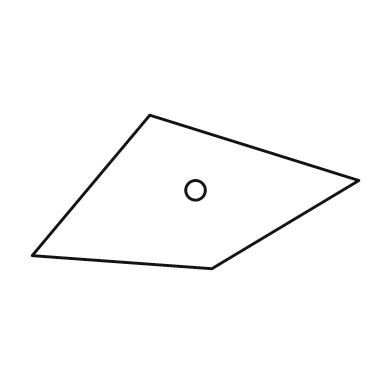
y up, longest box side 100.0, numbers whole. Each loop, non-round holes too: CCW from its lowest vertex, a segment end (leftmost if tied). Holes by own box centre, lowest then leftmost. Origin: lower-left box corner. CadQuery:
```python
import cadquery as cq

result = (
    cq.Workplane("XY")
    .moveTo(55.0, 0.0)
    .lineTo(100.0, 27.0)
    .lineTo(36.0, 47.0)
    .lineTo(0.0, 4.0)
    .close()
    .moveTo(50.0, 24.0)
    .circle(3.0)
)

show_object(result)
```